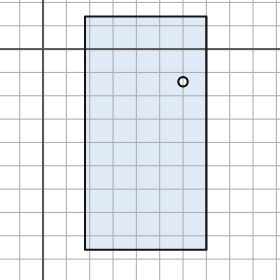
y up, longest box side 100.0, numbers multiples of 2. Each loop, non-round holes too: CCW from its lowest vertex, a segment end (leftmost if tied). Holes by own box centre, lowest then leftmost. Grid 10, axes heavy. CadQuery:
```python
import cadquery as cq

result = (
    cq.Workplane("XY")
    .moveTo(18.0, -86.0)
    .lineTo(70.0, -86.0)
    .lineTo(70.0, 14.0)
    .lineTo(18.0, 14.0)
    .close()
    .moveTo(60.0, -14.0)
    .circle(2.0)
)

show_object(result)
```